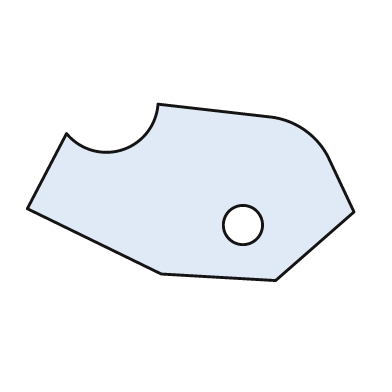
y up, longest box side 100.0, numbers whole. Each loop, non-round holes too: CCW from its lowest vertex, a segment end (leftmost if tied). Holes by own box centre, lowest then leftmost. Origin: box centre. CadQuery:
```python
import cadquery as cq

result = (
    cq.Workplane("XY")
    .moveTo(26.0, -27.0)
    .lineTo(50.0, -6.0)
    .lineTo(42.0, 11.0)
    .threePointArc((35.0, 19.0), (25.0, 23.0))
    .lineTo(-10.0, 27.0)
    .threePointArc((-21.0, 13.0), (-38.0, 18.0))
    .lineTo(-50.0, -5.0)
    .lineTo(-9.0, -25.0)
    .close()
    .moveTo(16.0, -10.0)
    .circle(6.0)
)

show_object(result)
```